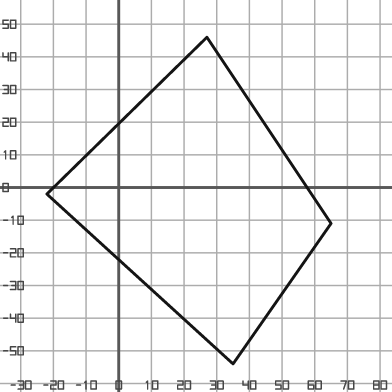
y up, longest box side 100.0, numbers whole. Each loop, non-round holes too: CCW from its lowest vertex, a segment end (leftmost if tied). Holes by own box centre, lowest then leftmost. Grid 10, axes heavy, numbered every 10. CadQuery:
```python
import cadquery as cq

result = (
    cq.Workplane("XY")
    .moveTo(35.0, -54.0)
    .lineTo(65.0, -11.0)
    .lineTo(27.0, 46.0)
    .lineTo(-22.0, -2.0)
    .close()
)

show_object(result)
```